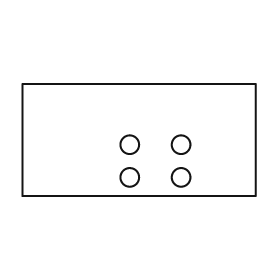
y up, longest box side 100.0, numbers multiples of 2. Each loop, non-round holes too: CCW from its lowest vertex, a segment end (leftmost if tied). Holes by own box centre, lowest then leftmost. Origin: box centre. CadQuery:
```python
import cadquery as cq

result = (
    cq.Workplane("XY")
    .moveTo(-50.0, -24.0)
    .lineTo(50.0, -24.0)
    .lineTo(50.0, 24.0)
    .lineTo(-50.0, 24.0)
    .close()
    .moveTo(-4.0, -16.0)
    .circle(4.0)
    .moveTo(18.0, -16.0)
    .circle(4.0)
    .moveTo(-4.0, -2.0)
    .circle(4.0)
    .moveTo(18.0, -2.0)
    .circle(4.0)
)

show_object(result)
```